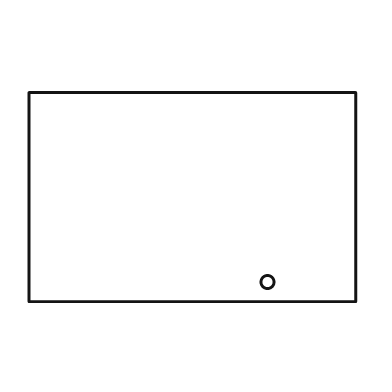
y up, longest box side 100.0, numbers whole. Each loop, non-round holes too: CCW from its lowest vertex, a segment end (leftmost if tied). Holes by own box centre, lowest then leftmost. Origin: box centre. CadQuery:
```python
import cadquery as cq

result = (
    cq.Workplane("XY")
    .moveTo(-50.0, -32.0)
    .lineTo(50.0, -32.0)
    .lineTo(50.0, 32.0)
    .lineTo(-50.0, 32.0)
    .close()
    .moveTo(23.0, -26.0)
    .circle(2.0)
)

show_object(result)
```